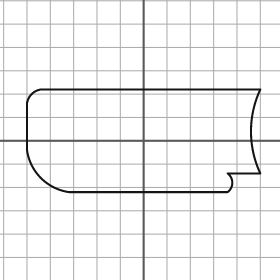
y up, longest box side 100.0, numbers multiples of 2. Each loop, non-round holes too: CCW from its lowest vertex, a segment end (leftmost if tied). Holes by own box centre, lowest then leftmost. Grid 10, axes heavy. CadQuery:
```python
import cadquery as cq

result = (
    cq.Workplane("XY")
    .moveTo(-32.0, -22.0)
    .lineTo(36.0, -22.0)
    .threePointArc((38.0, -18.0), (36.0, -14.0))
    .lineTo(50.0, -14.0)
    .threePointArc((46.0, 4.0), (50.0, 22.0))
    .lineTo(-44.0, 22.0)
    .threePointArc((-48.0, 20.0), (-50.0, 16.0))
    .lineTo(-50.0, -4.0)
    .threePointArc((-44.0, -16.0), (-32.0, -22.0))
    .close()
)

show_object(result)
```